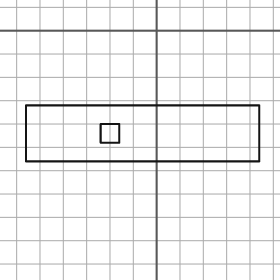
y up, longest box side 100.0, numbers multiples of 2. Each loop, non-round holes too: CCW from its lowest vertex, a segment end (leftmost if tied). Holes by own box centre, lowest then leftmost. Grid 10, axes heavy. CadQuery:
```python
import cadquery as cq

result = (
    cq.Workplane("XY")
    .moveTo(-56.0, -56.0)
    .lineTo(44.0, -56.0)
    .lineTo(44.0, -32.0)
    .lineTo(-56.0, -32.0)
    .close()
    .moveTo(-24.0, -48.0)
    .lineTo(-16.0, -48.0)
    .lineTo(-16.0, -40.0)
    .lineTo(-24.0, -40.0)
    .close()
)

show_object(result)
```